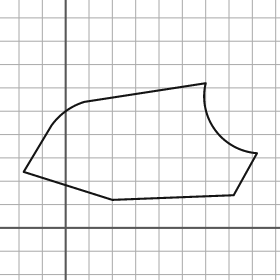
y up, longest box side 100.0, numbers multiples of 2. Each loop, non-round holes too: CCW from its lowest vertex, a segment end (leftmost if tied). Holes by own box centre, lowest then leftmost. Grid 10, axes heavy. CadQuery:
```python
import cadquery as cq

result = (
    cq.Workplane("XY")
    .moveTo(20.0, 12.0)
    .lineTo(72.0, 14.0)
    .lineTo(82.0, 32.0)
    .threePointArc((64.0, 42.0), (60.0, 62.0))
    .lineTo(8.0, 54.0)
    .threePointArc((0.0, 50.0), (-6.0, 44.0))
    .lineTo(-18.0, 24.0)
    .close()
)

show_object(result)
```